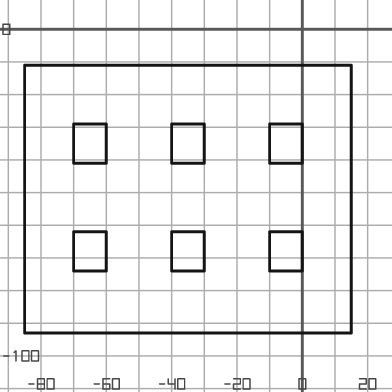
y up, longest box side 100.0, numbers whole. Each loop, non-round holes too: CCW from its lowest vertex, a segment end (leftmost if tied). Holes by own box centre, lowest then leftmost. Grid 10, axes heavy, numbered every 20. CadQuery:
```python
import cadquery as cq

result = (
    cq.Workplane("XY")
    .moveTo(-85.0, -93.0)
    .lineTo(15.0, -93.0)
    .lineTo(15.0, -11.0)
    .lineTo(-85.0, -11.0)
    .close()
    .moveTo(-70.0, -74.0)
    .lineTo(-60.0, -74.0)
    .lineTo(-60.0, -62.0)
    .lineTo(-70.0, -62.0)
    .close()
    .moveTo(-40.0, -74.0)
    .lineTo(-30.0, -74.0)
    .lineTo(-30.0, -62.0)
    .lineTo(-40.0, -62.0)
    .close()
    .moveTo(-10.0, -74.0)
    .lineTo(0.0, -74.0)
    .lineTo(0.0, -62.0)
    .lineTo(-10.0, -62.0)
    .close()
    .moveTo(-70.0, -41.0)
    .lineTo(-60.0, -41.0)
    .lineTo(-60.0, -29.0)
    .lineTo(-70.0, -29.0)
    .close()
    .moveTo(-40.0, -41.0)
    .lineTo(-30.0, -41.0)
    .lineTo(-30.0, -29.0)
    .lineTo(-40.0, -29.0)
    .close()
    .moveTo(-10.0, -41.0)
    .lineTo(0.0, -41.0)
    .lineTo(0.0, -29.0)
    .lineTo(-10.0, -29.0)
    .close()
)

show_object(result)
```